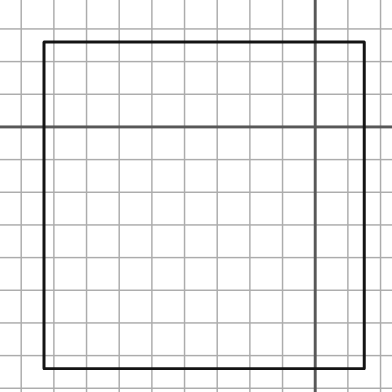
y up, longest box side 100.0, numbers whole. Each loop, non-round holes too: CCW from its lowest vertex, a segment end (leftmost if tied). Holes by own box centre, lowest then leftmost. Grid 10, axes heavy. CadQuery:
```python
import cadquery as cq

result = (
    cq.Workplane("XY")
    .moveTo(-83.0, -74.0)
    .lineTo(15.0, -74.0)
    .lineTo(15.0, 26.0)
    .lineTo(-83.0, 26.0)
    .close()
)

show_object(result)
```